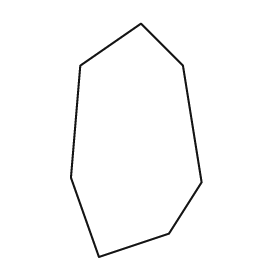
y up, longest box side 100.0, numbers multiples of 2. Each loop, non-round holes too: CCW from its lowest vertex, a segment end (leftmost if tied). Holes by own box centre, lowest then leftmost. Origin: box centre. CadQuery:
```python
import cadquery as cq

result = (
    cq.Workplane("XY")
    .moveTo(-16.0, -50.0)
    .lineTo(14.0, -40.0)
    .lineTo(28.0, -18.0)
    .lineTo(20.0, 32.0)
    .lineTo(2.0, 50.0)
    .lineTo(-24.0, 32.0)
    .lineTo(-28.0, -16.0)
    .close()
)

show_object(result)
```